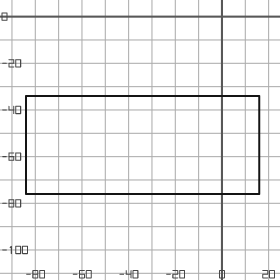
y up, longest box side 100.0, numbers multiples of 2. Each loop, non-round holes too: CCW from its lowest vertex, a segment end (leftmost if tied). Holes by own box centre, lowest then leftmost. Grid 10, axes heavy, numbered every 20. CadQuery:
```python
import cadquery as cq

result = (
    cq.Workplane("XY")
    .moveTo(-84.0, -76.0)
    .lineTo(16.0, -76.0)
    .lineTo(16.0, -34.0)
    .lineTo(-84.0, -34.0)
    .close()
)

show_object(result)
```